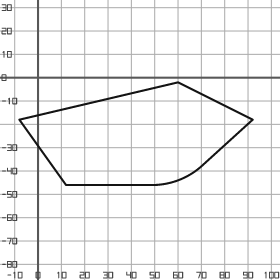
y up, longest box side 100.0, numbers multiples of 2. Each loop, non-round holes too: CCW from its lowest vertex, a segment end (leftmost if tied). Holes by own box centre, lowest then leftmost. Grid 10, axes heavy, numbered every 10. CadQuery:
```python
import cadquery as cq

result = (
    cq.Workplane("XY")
    .moveTo(12.0, -46.0)
    .lineTo(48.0, -46.0)
    .threePointArc((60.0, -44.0), (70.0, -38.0))
    .lineTo(92.0, -18.0)
    .lineTo(60.0, -2.0)
    .lineTo(-8.0, -18.0)
    .close()
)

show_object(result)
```